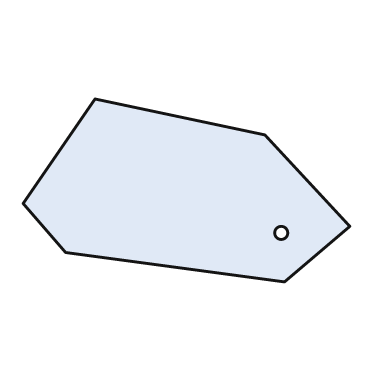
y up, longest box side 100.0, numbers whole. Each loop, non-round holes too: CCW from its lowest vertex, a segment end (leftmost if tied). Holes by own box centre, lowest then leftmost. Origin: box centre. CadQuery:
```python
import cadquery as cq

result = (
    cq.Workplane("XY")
    .moveTo(30.0, -28.0)
    .lineTo(50.0, -11.0)
    .lineTo(24.0, 17.0)
    .lineTo(-28.0, 28.0)
    .lineTo(-50.0, -4.0)
    .lineTo(-37.0, -19.0)
    .close()
    .moveTo(29.0, -13.0)
    .circle(2.0)
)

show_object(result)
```